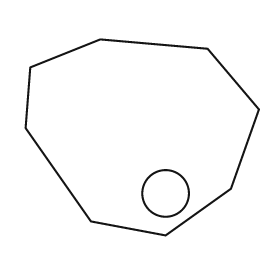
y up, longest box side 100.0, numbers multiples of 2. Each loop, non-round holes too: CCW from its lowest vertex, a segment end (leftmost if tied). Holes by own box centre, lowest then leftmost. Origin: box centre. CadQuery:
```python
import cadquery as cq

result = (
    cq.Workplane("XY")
    .moveTo(10.0, -42.0)
    .lineTo(38.0, -22.0)
    .lineTo(50.0, 12.0)
    .lineTo(28.0, 38.0)
    .lineTo(-18.0, 42.0)
    .lineTo(-48.0, 30.0)
    .lineTo(-50.0, 4.0)
    .lineTo(-22.0, -36.0)
    .close()
    .moveTo(10.0, -24.0)
    .circle(10.0)
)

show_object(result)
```